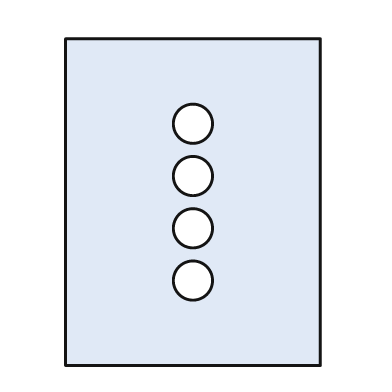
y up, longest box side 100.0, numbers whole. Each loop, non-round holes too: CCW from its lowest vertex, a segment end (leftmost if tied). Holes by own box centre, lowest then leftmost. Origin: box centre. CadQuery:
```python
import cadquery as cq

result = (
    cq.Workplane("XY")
    .moveTo(-39.0, -50.0)
    .lineTo(39.0, -50.0)
    .lineTo(39.0, 50.0)
    .lineTo(-39.0, 50.0)
    .close()
    .moveTo(0.0, -24.0)
    .circle(6.0)
    .moveTo(0.0, -8.0)
    .circle(6.0)
    .moveTo(0.0, 8.0)
    .circle(6.0)
    .moveTo(0.0, 24.0)
    .circle(6.0)
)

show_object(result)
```